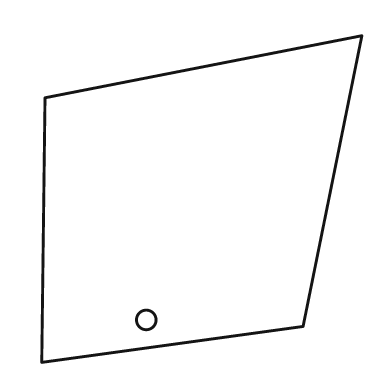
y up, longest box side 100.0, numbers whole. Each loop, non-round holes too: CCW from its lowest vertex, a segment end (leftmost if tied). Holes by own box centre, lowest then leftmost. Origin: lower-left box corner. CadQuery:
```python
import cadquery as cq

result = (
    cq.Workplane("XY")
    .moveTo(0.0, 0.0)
    .lineTo(80.0, 11.0)
    .lineTo(98.0, 100.0)
    .lineTo(1.0, 81.0)
    .close()
    .moveTo(32.0, 13.0)
    .circle(3.0)
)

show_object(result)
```